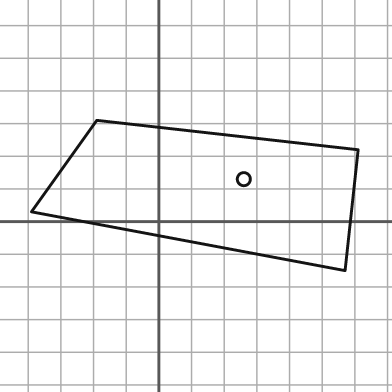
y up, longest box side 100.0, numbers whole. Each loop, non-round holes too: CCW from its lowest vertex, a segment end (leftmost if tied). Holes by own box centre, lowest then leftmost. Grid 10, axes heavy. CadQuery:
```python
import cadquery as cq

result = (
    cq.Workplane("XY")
    .moveTo(57.0, -15.0)
    .lineTo(61.0, 22.0)
    .lineTo(-19.0, 31.0)
    .lineTo(-39.0, 3.0)
    .close()
    .moveTo(26.0, 13.0)
    .circle(2.0)
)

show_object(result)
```